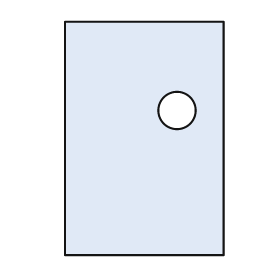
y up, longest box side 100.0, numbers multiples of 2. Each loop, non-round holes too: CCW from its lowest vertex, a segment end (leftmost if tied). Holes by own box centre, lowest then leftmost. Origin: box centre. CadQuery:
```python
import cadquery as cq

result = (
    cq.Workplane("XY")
    .moveTo(-34.0, -50.0)
    .lineTo(34.0, -50.0)
    .lineTo(34.0, 50.0)
    .lineTo(-34.0, 50.0)
    .close()
    .moveTo(14.0, 12.0)
    .circle(8.0)
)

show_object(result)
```